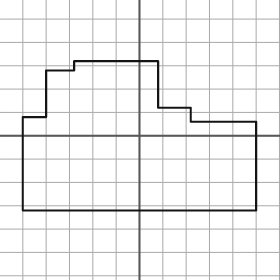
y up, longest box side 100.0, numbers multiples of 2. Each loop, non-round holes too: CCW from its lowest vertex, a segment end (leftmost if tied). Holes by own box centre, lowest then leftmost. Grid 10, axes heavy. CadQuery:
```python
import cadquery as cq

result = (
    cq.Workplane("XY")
    .moveTo(-50.0, -32.0)
    .lineTo(50.0, -32.0)
    .lineTo(50.0, 6.0)
    .lineTo(22.0, 6.0)
    .lineTo(22.0, 12.0)
    .lineTo(8.0, 12.0)
    .lineTo(8.0, 32.0)
    .lineTo(-28.0, 32.0)
    .lineTo(-28.0, 28.0)
    .lineTo(-40.0, 28.0)
    .lineTo(-40.0, 8.0)
    .lineTo(-50.0, 8.0)
    .close()
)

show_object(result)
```